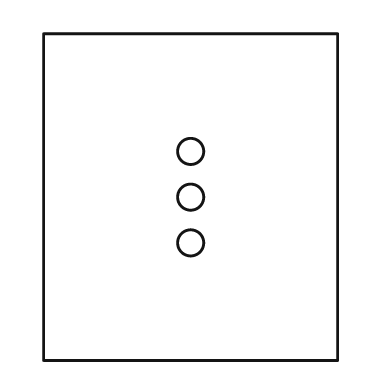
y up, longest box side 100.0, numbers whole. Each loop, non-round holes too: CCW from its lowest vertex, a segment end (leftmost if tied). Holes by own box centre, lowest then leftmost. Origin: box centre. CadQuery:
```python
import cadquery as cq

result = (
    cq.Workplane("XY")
    .moveTo(-45.0, -50.0)
    .lineTo(45.0, -50.0)
    .lineTo(45.0, 50.0)
    .lineTo(-45.0, 50.0)
    .close()
    .moveTo(0.0, -14.0)
    .circle(4.0)
    .moveTo(0.0, 0.0)
    .circle(4.0)
    .moveTo(0.0, 14.0)
    .circle(4.0)
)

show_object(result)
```